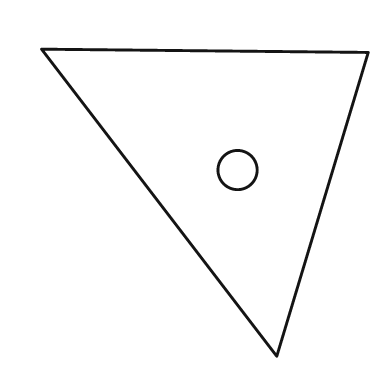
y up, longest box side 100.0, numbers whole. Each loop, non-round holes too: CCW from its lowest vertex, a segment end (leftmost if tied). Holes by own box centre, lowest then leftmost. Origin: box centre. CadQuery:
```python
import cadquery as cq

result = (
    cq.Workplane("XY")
    .moveTo(22.0, -47.0)
    .lineTo(50.0, 46.0)
    .lineTo(-50.0, 47.0)
    .close()
    .moveTo(10.0, 10.0)
    .circle(6.0)
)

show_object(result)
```